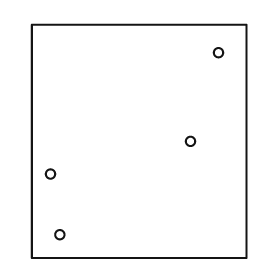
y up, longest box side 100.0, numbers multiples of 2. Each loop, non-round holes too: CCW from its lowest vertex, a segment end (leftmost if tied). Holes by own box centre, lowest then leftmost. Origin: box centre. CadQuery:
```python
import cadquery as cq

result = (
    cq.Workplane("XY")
    .moveTo(-46.0, -50.0)
    .lineTo(46.0, -50.0)
    .lineTo(46.0, 50.0)
    .lineTo(-46.0, 50.0)
    .close()
    .moveTo(-34.0, -40.0)
    .circle(2.0)
    .moveTo(-38.0, -14.0)
    .circle(2.0)
    .moveTo(22.0, 0.0)
    .circle(2.0)
    .moveTo(34.0, 38.0)
    .circle(2.0)
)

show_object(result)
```